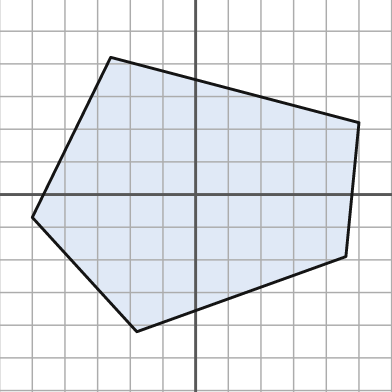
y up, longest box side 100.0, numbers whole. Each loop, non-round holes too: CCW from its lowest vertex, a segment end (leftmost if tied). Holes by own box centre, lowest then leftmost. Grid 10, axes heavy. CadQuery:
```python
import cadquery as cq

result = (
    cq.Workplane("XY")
    .moveTo(-18.0, -42.0)
    .lineTo(46.0, -19.0)
    .lineTo(50.0, 22.0)
    .lineTo(-26.0, 42.0)
    .lineTo(-50.0, -7.0)
    .close()
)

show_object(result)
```